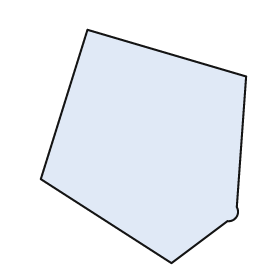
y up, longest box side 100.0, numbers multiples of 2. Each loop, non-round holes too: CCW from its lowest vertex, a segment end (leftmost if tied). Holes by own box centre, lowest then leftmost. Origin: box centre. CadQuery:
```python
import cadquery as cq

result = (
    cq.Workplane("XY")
    .moveTo(12.0, -50.0)
    .lineTo(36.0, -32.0)
    .threePointArc((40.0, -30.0), (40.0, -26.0))
    .lineTo(44.0, 30.0)
    .lineTo(-24.0, 50.0)
    .lineTo(-44.0, -14.0)
    .close()
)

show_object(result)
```